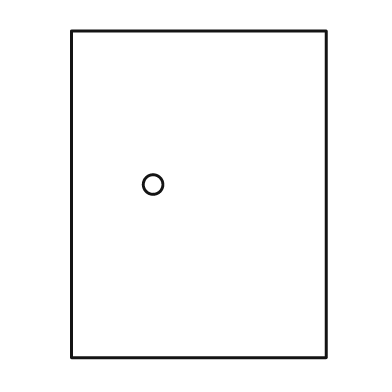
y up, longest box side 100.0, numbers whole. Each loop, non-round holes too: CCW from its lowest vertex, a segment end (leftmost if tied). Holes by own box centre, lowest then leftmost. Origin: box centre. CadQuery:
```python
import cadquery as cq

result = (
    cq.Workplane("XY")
    .moveTo(-39.0, -50.0)
    .lineTo(39.0, -50.0)
    .lineTo(39.0, 50.0)
    .lineTo(-39.0, 50.0)
    .close()
    .moveTo(-14.0, 3.0)
    .circle(3.0)
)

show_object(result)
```